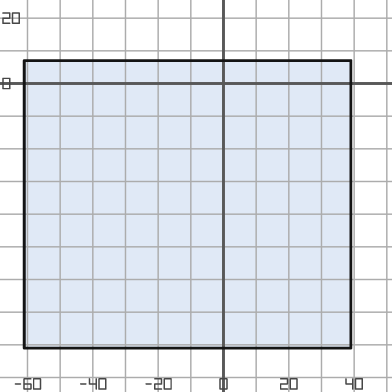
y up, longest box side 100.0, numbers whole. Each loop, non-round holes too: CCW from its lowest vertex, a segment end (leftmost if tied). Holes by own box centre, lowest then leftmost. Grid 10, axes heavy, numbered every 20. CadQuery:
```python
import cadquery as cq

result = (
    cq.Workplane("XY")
    .moveTo(-61.0, -81.0)
    .lineTo(39.0, -81.0)
    .lineTo(39.0, 7.0)
    .lineTo(-61.0, 7.0)
    .close()
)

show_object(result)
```